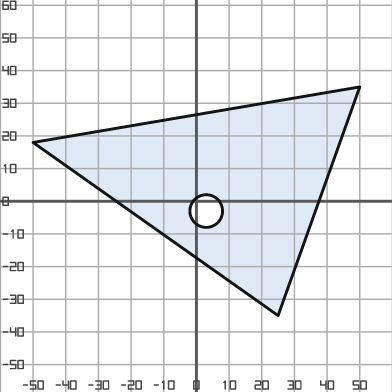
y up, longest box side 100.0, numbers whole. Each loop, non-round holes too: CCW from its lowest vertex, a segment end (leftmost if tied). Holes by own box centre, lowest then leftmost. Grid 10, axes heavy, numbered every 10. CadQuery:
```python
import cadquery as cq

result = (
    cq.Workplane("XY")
    .moveTo(25.0, -35.0)
    .lineTo(50.0, 35.0)
    .lineTo(-50.0, 18.0)
    .close()
    .moveTo(3.0, -3.0)
    .circle(5.0)
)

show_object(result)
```